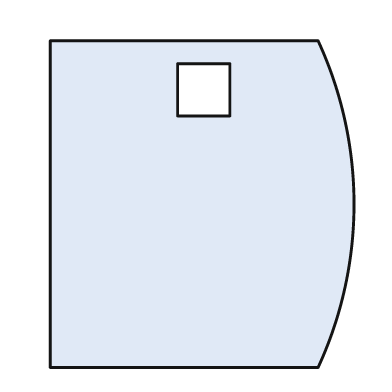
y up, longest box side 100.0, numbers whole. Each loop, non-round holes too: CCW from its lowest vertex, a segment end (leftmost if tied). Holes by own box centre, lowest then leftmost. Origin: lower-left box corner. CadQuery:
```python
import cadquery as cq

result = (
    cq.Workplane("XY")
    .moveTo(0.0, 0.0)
    .lineTo(82.0, 0.0)
    .threePointArc((93.0, 50.0), (82.0, 100.0))
    .lineTo(0.0, 100.0)
    .close()
    .moveTo(39.0, 77.0)
    .lineTo(55.0, 77.0)
    .lineTo(55.0, 93.0)
    .lineTo(39.0, 93.0)
    .close()
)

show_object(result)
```